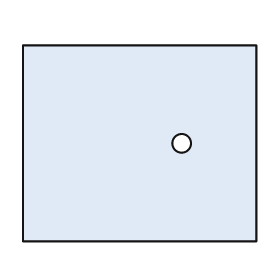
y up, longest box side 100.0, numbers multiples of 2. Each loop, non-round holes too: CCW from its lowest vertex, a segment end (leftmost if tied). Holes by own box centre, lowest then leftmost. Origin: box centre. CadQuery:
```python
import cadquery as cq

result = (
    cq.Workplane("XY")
    .moveTo(-50.0, -42.0)
    .lineTo(50.0, -42.0)
    .lineTo(50.0, 42.0)
    .lineTo(-50.0, 42.0)
    .close()
    .moveTo(18.0, 0.0)
    .circle(4.0)
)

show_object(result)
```